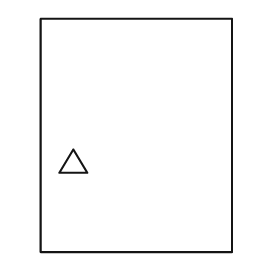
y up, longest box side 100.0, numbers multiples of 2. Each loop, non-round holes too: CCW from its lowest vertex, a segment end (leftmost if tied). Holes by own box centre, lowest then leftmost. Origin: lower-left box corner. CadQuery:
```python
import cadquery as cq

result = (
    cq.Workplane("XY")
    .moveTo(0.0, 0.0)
    .lineTo(82.0, 0.0)
    .lineTo(82.0, 100.0)
    .lineTo(0.0, 100.0)
    .close()
    .moveTo(8.0, 34.0)
    .lineTo(20.0, 34.0)
    .lineTo(14.0, 44.0)
    .close()
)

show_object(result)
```